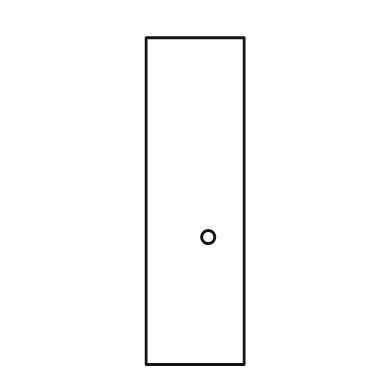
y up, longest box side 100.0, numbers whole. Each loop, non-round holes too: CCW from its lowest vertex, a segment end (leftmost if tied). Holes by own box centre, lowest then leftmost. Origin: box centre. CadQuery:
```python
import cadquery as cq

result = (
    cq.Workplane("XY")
    .moveTo(-15.0, -50.0)
    .lineTo(15.0, -50.0)
    .lineTo(15.0, 50.0)
    .lineTo(-15.0, 50.0)
    .close()
    .moveTo(4.0, -11.0)
    .circle(2.0)
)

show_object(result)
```